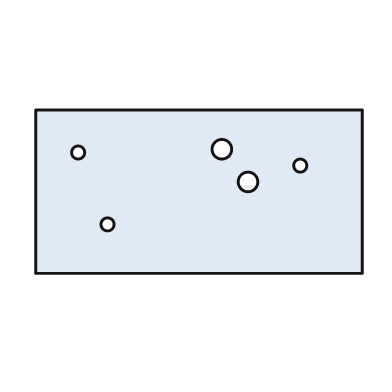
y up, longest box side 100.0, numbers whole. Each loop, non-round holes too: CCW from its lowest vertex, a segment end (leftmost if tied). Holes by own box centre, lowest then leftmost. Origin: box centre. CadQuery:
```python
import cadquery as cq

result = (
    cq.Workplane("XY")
    .moveTo(-50.0, -25.0)
    .lineTo(50.0, -25.0)
    .lineTo(50.0, 25.0)
    .lineTo(-50.0, 25.0)
    .close()
    .moveTo(-28.0, -10.0)
    .circle(2.0)
    .moveTo(15.0, 3.0)
    .circle(3.0)
    .moveTo(31.0, 8.0)
    .circle(2.0)
    .moveTo(-37.0, 12.0)
    .circle(2.0)
    .moveTo(7.0, 13.0)
    .circle(3.0)
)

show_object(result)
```